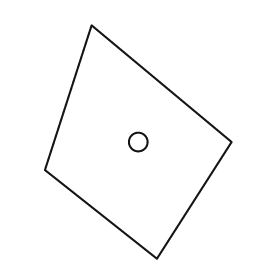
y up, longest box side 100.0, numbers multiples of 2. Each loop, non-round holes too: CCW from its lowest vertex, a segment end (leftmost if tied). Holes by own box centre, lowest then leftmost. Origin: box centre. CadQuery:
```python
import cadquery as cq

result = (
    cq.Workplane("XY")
    .moveTo(8.0, -50.0)
    .lineTo(40.0, 0.0)
    .lineTo(-20.0, 50.0)
    .lineTo(-40.0, -12.0)
    .close()
    .moveTo(0.0, 0.0)
    .circle(4.0)
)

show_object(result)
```